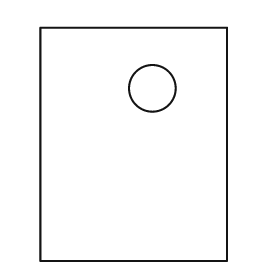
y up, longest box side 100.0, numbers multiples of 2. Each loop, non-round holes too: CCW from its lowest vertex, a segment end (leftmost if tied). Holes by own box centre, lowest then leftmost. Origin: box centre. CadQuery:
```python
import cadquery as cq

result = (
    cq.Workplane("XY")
    .moveTo(-40.0, -50.0)
    .lineTo(40.0, -50.0)
    .lineTo(40.0, 50.0)
    .lineTo(-40.0, 50.0)
    .close()
    .moveTo(8.0, 24.0)
    .circle(10.0)
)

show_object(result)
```